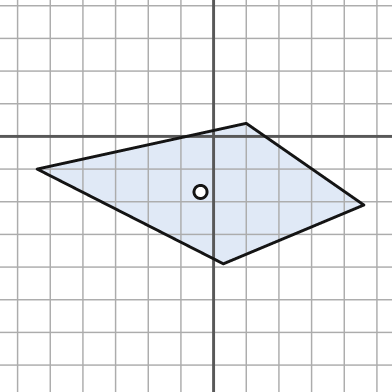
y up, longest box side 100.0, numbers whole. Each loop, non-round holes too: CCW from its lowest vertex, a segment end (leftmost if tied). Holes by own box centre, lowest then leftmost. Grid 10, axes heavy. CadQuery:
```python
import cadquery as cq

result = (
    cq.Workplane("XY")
    .moveTo(3.0, -39.0)
    .lineTo(46.0, -21.0)
    .lineTo(10.0, 4.0)
    .lineTo(-54.0, -10.0)
    .close()
    .moveTo(-4.0, -17.0)
    .circle(2.0)
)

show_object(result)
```